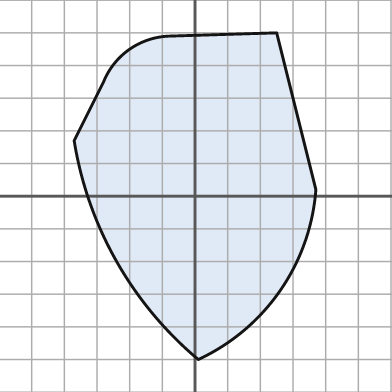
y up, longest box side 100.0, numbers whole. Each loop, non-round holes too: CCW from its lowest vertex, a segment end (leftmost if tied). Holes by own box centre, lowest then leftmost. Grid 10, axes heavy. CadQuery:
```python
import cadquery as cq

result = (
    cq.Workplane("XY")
    .moveTo(1.0, -50.0)
    .threePointArc((26.0, -29.0), (37.0, 2.0))
    .lineTo(25.0, 50.0)
    .lineTo(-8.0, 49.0)
    .threePointArc((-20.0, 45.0), (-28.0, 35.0))
    .lineTo(-37.0, 17.0)
    .threePointArc((-24.0, -20.0), (1.0, -50.0))
    .close()
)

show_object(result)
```